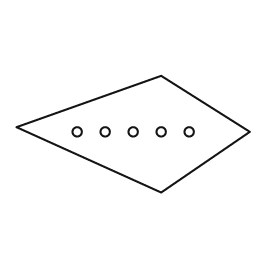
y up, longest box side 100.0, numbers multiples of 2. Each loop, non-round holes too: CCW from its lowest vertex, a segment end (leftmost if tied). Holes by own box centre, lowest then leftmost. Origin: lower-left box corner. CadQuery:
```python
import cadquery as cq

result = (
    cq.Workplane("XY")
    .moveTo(62.0, 0.0)
    .lineTo(100.0, 26.0)
    .lineTo(62.0, 50.0)
    .lineTo(0.0, 28.0)
    .close()
    .moveTo(26.0, 26.0)
    .circle(2.0)
    .moveTo(38.0, 26.0)
    .circle(2.0)
    .moveTo(50.0, 26.0)
    .circle(2.0)
    .moveTo(62.0, 26.0)
    .circle(2.0)
    .moveTo(74.0, 26.0)
    .circle(2.0)
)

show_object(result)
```